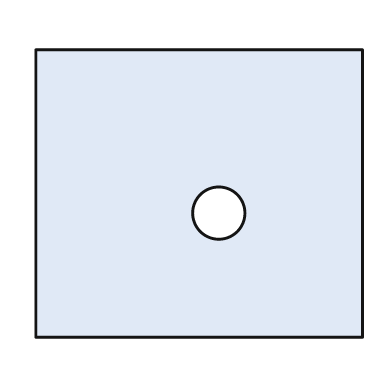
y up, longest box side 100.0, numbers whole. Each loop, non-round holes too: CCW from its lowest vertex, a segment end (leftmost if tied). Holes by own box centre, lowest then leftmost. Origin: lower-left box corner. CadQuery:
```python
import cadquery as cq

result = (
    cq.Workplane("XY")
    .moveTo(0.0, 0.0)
    .lineTo(100.0, 0.0)
    .lineTo(100.0, 88.0)
    .lineTo(0.0, 88.0)
    .close()
    .moveTo(56.0, 38.0)
    .circle(8.0)
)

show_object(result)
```